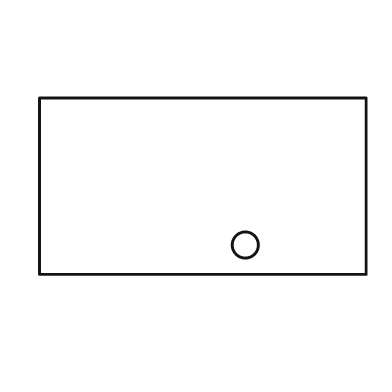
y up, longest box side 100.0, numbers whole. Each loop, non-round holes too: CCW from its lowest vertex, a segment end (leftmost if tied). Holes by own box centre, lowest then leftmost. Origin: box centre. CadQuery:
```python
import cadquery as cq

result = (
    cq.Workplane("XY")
    .moveTo(-50.0, -27.0)
    .lineTo(50.0, -27.0)
    .lineTo(50.0, 27.0)
    .lineTo(-50.0, 27.0)
    .close()
    .moveTo(13.0, -18.0)
    .circle(4.0)
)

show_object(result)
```